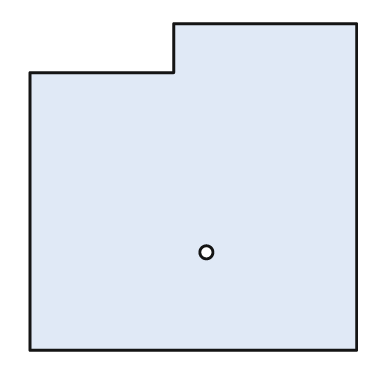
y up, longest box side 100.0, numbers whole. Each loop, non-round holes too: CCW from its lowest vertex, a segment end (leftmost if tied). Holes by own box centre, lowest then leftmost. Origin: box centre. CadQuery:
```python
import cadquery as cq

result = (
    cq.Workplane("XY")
    .moveTo(-50.0, -50.0)
    .lineTo(50.0, -50.0)
    .lineTo(50.0, 50.0)
    .lineTo(-6.0, 50.0)
    .lineTo(-6.0, 35.0)
    .lineTo(-50.0, 35.0)
    .close()
    .moveTo(4.0, -20.0)
    .circle(2.0)
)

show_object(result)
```